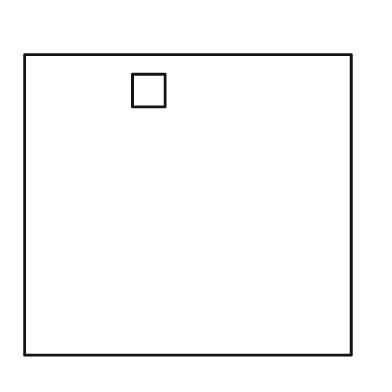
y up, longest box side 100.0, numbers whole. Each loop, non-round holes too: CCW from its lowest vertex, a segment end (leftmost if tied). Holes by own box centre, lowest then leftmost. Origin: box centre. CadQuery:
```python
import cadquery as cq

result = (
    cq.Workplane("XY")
    .moveTo(-50.0, -46.0)
    .lineTo(50.0, -46.0)
    .lineTo(50.0, 46.0)
    .lineTo(-50.0, 46.0)
    .close()
    .moveTo(-17.0, 30.0)
    .lineTo(-7.0, 30.0)
    .lineTo(-7.0, 40.0)
    .lineTo(-17.0, 40.0)
    .close()
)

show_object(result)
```